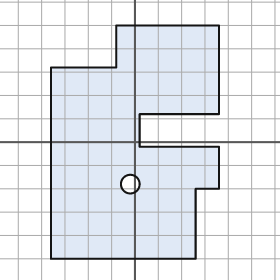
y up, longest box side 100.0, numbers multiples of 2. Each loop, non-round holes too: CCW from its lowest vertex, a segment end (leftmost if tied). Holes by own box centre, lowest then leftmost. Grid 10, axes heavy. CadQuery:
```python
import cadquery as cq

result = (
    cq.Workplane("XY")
    .moveTo(-36.0, -50.0)
    .lineTo(26.0, -50.0)
    .lineTo(26.0, -20.0)
    .lineTo(36.0, -20.0)
    .lineTo(36.0, -2.0)
    .lineTo(2.0, -2.0)
    .lineTo(2.0, 12.0)
    .lineTo(36.0, 12.0)
    .lineTo(36.0, 50.0)
    .lineTo(-8.0, 50.0)
    .lineTo(-8.0, 32.0)
    .lineTo(-36.0, 32.0)
    .close()
    .moveTo(-2.0, -18.0)
    .circle(4.0)
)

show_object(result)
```